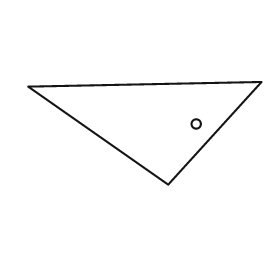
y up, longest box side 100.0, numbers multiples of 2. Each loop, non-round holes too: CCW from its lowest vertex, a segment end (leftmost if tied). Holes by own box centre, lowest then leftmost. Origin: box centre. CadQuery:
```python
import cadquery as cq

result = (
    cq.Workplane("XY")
    .moveTo(10.0, -22.0)
    .lineTo(50.0, 22.0)
    .lineTo(-50.0, 20.0)
    .close()
    .moveTo(22.0, 4.0)
    .circle(2.0)
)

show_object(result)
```